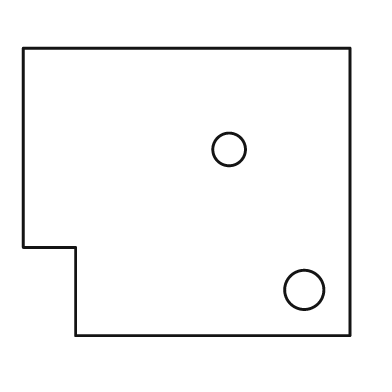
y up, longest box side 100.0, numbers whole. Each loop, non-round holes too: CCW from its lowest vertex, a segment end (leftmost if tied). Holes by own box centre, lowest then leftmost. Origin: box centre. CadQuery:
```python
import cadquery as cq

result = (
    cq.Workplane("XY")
    .moveTo(-34.0, -44.0)
    .lineTo(50.0, -44.0)
    .lineTo(50.0, 44.0)
    .lineTo(-50.0, 44.0)
    .lineTo(-50.0, -17.0)
    .lineTo(-34.0, -17.0)
    .close()
    .moveTo(36.0, -30.0)
    .circle(6.0)
    .moveTo(13.0, 13.0)
    .circle(5.0)
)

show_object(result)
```